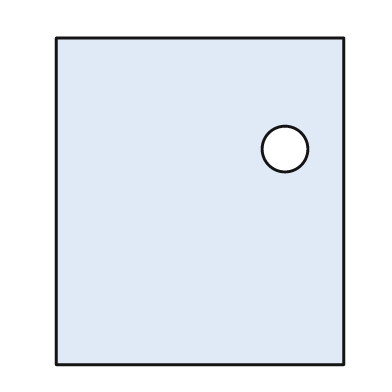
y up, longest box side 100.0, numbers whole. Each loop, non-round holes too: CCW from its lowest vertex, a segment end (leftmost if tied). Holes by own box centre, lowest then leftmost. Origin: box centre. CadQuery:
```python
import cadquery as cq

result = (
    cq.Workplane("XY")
    .moveTo(-44.0, -50.0)
    .lineTo(44.0, -50.0)
    .lineTo(44.0, 50.0)
    .lineTo(-44.0, 50.0)
    .close()
    .moveTo(26.0, 16.0)
    .circle(7.0)
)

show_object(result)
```